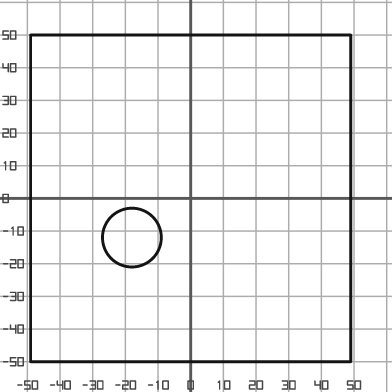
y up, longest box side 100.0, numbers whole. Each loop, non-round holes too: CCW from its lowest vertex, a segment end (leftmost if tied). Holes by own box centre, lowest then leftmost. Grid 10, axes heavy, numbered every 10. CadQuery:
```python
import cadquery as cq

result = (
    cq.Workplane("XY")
    .moveTo(-49.0, -50.0)
    .lineTo(49.0, -50.0)
    .lineTo(49.0, 50.0)
    .lineTo(-49.0, 50.0)
    .close()
    .moveTo(-18.0, -12.0)
    .circle(9.0)
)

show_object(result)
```